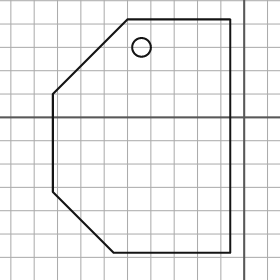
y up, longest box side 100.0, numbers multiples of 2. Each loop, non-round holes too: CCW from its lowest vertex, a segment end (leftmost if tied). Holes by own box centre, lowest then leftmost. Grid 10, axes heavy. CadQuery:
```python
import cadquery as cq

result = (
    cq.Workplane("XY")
    .moveTo(-56.0, -58.0)
    .lineTo(-6.0, -58.0)
    .lineTo(-6.0, 42.0)
    .lineTo(-50.0, 42.0)
    .lineTo(-82.0, 10.0)
    .lineTo(-82.0, -32.0)
    .close()
    .moveTo(-44.0, 30.0)
    .circle(4.0)
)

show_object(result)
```